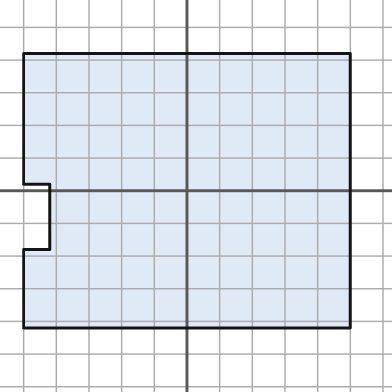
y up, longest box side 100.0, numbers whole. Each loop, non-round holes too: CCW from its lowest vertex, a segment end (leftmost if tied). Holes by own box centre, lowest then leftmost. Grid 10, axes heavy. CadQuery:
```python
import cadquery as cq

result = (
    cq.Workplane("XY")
    .moveTo(-50.0, -42.0)
    .lineTo(50.0, -42.0)
    .lineTo(50.0, 42.0)
    .lineTo(-50.0, 42.0)
    .lineTo(-50.0, 2.0)
    .lineTo(-42.0, 2.0)
    .lineTo(-42.0, -18.0)
    .lineTo(-50.0, -18.0)
    .close()
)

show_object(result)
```